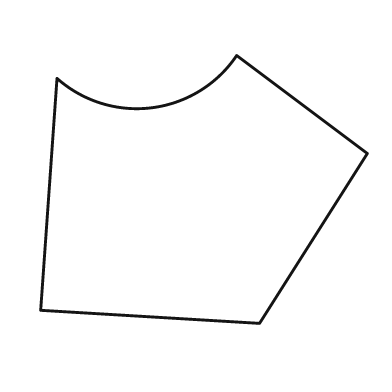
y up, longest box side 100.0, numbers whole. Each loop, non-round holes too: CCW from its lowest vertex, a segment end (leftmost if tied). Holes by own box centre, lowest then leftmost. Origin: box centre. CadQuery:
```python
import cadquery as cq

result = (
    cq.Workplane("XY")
    .moveTo(17.0, -41.0)
    .lineTo(50.0, 11.0)
    .lineTo(10.0, 41.0)
    .threePointArc((-16.0, 25.0), (-45.0, 34.0))
    .lineTo(-50.0, -37.0)
    .close()
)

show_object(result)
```